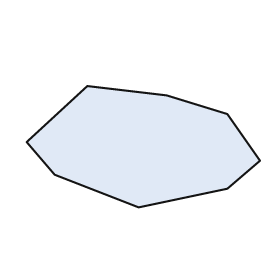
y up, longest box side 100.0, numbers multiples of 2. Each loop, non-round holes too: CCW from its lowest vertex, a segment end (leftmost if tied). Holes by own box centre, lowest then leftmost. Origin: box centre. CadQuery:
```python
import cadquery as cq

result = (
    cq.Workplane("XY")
    .moveTo(-2.0, -26.0)
    .lineTo(36.0, -18.0)
    .lineTo(50.0, -6.0)
    .lineTo(36.0, 14.0)
    .lineTo(10.0, 22.0)
    .lineTo(-24.0, 26.0)
    .lineTo(-50.0, 2.0)
    .lineTo(-38.0, -12.0)
    .close()
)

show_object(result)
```